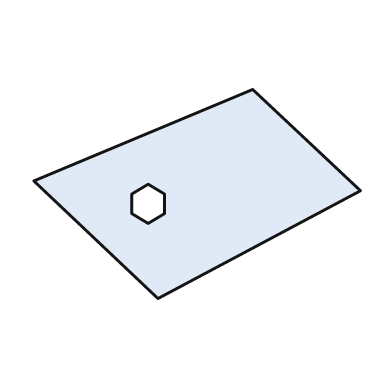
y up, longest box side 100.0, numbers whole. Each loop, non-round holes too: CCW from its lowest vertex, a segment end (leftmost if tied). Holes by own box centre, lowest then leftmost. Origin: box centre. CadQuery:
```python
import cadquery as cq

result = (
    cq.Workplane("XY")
    .moveTo(-12.0, -32.0)
    .lineTo(50.0, 1.0)
    .lineTo(17.0, 32.0)
    .lineTo(-50.0, 4.0)
    .close()
    .moveTo(-15.0, -9.0)
    .lineTo(-10.0, -6.0)
    .lineTo(-10.0, 0.0)
    .lineTo(-15.0, 3.0)
    .lineTo(-20.0, 0.0)
    .lineTo(-20.0, -6.0)
    .close()
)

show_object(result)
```